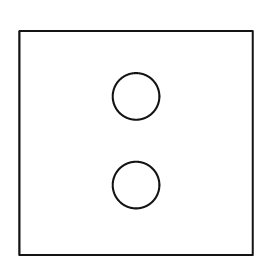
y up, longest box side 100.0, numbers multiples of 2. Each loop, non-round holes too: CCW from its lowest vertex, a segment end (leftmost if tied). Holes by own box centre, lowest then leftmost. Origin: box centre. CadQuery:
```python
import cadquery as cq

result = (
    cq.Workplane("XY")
    .moveTo(-50.0, -48.0)
    .lineTo(50.0, -48.0)
    .lineTo(50.0, 48.0)
    .lineTo(-50.0, 48.0)
    .close()
    .moveTo(0.0, -18.0)
    .circle(10.0)
    .moveTo(0.0, 20.0)
    .circle(10.0)
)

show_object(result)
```